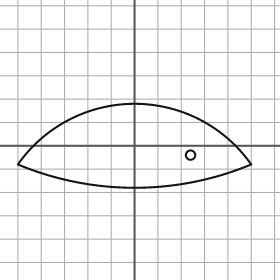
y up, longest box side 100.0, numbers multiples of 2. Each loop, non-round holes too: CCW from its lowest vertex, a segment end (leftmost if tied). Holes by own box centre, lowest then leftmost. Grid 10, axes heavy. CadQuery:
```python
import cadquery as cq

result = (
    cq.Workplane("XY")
    .moveTo(-50.0, -8.0)
    .threePointArc((0.0, -18.0), (50.0, -8.0))
    .threePointArc((0.0, 18.0), (-50.0, -8.0))
    .close()
    .moveTo(24.0, -4.0)
    .circle(2.0)
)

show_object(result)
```